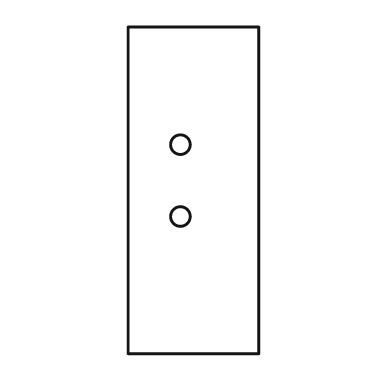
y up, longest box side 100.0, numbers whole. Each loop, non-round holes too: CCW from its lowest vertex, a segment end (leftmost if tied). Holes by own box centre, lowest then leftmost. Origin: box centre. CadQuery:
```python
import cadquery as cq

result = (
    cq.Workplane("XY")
    .moveTo(-20.0, -50.0)
    .lineTo(20.0, -50.0)
    .lineTo(20.0, 50.0)
    .lineTo(-20.0, 50.0)
    .close()
    .moveTo(-4.0, -8.0)
    .circle(3.0)
    .moveTo(-4.0, 14.0)
    .circle(3.0)
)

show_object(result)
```